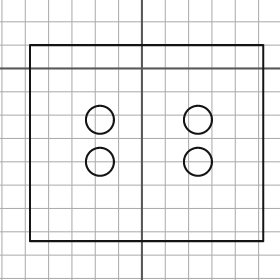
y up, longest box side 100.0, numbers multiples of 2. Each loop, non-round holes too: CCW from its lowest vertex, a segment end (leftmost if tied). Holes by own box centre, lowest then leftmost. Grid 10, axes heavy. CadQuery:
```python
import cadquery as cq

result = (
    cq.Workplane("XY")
    .moveTo(-48.0, -74.0)
    .lineTo(52.0, -74.0)
    .lineTo(52.0, 10.0)
    .lineTo(-48.0, 10.0)
    .close()
    .moveTo(-18.0, -40.0)
    .circle(6.0)
    .moveTo(24.0, -40.0)
    .circle(6.0)
    .moveTo(-18.0, -22.0)
    .circle(6.0)
    .moveTo(24.0, -22.0)
    .circle(6.0)
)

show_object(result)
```